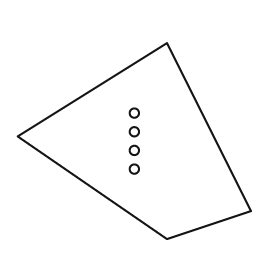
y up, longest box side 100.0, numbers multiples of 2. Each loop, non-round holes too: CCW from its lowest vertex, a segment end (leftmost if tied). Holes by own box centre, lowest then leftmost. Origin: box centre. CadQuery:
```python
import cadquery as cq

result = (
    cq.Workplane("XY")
    .moveTo(14.0, -42.0)
    .lineTo(50.0, -30.0)
    .lineTo(14.0, 42.0)
    .lineTo(-50.0, 2.0)
    .close()
    .moveTo(0.0, -12.0)
    .circle(2.0)
    .moveTo(0.0, -4.0)
    .circle(2.0)
    .moveTo(0.0, 4.0)
    .circle(2.0)
    .moveTo(0.0, 12.0)
    .circle(2.0)
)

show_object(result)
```